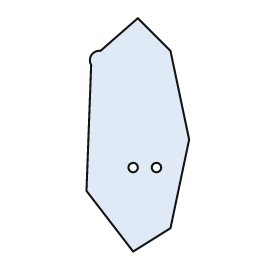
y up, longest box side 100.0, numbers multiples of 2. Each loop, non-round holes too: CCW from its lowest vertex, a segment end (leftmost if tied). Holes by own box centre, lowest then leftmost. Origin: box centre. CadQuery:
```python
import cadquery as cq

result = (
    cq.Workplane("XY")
    .moveTo(-2.0, -50.0)
    .lineTo(14.0, -40.0)
    .lineTo(22.0, -2.0)
    .lineTo(14.0, 36.0)
    .lineTo(0.0, 50.0)
    .lineTo(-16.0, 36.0)
    .threePointArc((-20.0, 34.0), (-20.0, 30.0))
    .lineTo(-22.0, -24.0)
    .close()
    .moveTo(-2.0, -14.0)
    .circle(2.0)
    .moveTo(8.0, -14.0)
    .circle(2.0)
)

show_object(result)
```